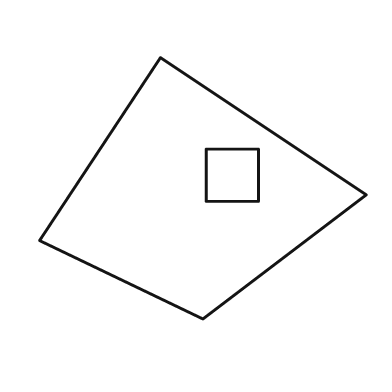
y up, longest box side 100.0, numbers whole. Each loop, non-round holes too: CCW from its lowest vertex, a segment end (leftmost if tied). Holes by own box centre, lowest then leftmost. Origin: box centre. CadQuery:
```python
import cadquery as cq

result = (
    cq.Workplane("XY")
    .moveTo(0.0, -40.0)
    .lineTo(50.0, -2.0)
    .lineTo(-13.0, 40.0)
    .lineTo(-50.0, -16.0)
    .close()
    .moveTo(1.0, -4.0)
    .lineTo(17.0, -4.0)
    .lineTo(17.0, 12.0)
    .lineTo(1.0, 12.0)
    .close()
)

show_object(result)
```